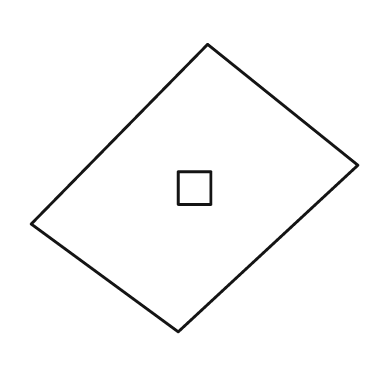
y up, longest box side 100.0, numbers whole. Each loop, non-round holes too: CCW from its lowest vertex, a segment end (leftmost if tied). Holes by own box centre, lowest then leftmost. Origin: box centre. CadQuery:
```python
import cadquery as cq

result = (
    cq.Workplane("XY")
    .moveTo(-5.0, -44.0)
    .lineTo(50.0, 7.0)
    .lineTo(4.0, 44.0)
    .lineTo(-50.0, -11.0)
    .close()
    .moveTo(-5.0, -5.0)
    .lineTo(5.0, -5.0)
    .lineTo(5.0, 5.0)
    .lineTo(-5.0, 5.0)
    .close()
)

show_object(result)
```